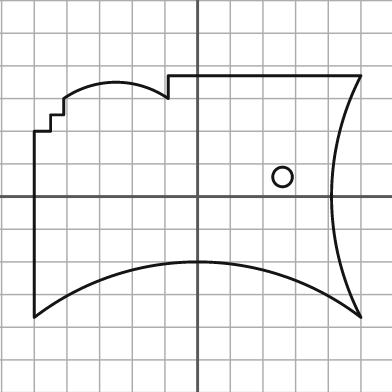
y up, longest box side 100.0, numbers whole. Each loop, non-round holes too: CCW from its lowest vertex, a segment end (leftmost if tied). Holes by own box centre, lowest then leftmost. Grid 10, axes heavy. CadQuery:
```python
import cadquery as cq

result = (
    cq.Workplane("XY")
    .moveTo(-50.0, -37.0)
    .threePointArc((0.0, -20.0), (50.0, -37.0))
    .threePointArc((41.0, 0.0), (50.0, 37.0))
    .lineTo(-9.0, 37.0)
    .lineTo(-9.0, 30.0)
    .threePointArc((-25.0, 35.0), (-41.0, 30.0))
    .lineTo(-41.0, 25.0)
    .lineTo(-45.0, 25.0)
    .lineTo(-45.0, 20.0)
    .lineTo(-50.0, 20.0)
    .close()
    .moveTo(26.0, 6.0)
    .circle(3.0)
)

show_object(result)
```